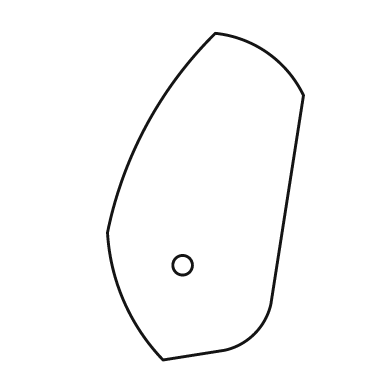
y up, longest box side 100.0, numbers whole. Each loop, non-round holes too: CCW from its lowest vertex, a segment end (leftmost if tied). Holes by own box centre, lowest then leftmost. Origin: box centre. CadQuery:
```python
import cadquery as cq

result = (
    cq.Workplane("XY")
    .moveTo(-13.0, -50.0)
    .lineTo(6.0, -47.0)
    .threePointArc((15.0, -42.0), (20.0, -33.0))
    .lineTo(30.0, 31.0)
    .threePointArc((19.0, 44.0), (3.0, 50.0))
    .threePointArc((-18.0, 22.0), (-30.0, -11.0))
    .threePointArc((-25.0, -32.0), (-13.0, -50.0))
    .close()
    .moveTo(-7.0, -21.0)
    .circle(3.0)
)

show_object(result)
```